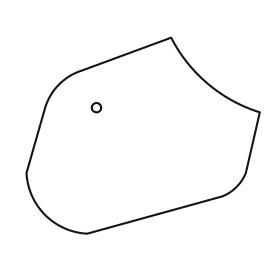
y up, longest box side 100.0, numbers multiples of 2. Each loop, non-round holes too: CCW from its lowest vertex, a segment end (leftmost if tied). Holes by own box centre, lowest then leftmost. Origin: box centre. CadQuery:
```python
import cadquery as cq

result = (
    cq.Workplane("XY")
    .moveTo(-24.0, -42.0)
    .lineTo(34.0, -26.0)
    .threePointArc((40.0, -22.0), (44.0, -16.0))
    .lineTo(50.0, 10.0)
    .threePointArc((28.0, 22.0), (12.0, 42.0))
    .lineTo(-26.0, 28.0)
    .threePointArc((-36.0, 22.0), (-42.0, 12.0))
    .lineTo(-50.0, -16.0)
    .threePointArc((-42.0, -34.0), (-24.0, -42.0))
    .close()
    .moveTo(-20.0, 12.0)
    .circle(2.0)
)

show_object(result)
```